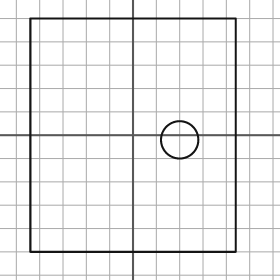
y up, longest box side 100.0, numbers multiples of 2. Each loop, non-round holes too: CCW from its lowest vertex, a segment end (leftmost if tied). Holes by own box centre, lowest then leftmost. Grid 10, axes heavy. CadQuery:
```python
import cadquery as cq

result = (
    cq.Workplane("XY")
    .moveTo(-44.0, -50.0)
    .lineTo(44.0, -50.0)
    .lineTo(44.0, 50.0)
    .lineTo(-44.0, 50.0)
    .close()
    .moveTo(20.0, -2.0)
    .circle(8.0)
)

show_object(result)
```